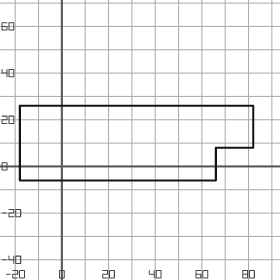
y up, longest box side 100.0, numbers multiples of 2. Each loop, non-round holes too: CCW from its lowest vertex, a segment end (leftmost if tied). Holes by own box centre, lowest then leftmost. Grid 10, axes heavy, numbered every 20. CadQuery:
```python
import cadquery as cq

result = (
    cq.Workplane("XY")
    .moveTo(-18.0, -6.0)
    .lineTo(66.0, -6.0)
    .lineTo(66.0, 8.0)
    .lineTo(82.0, 8.0)
    .lineTo(82.0, 26.0)
    .lineTo(-18.0, 26.0)
    .close()
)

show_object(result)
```